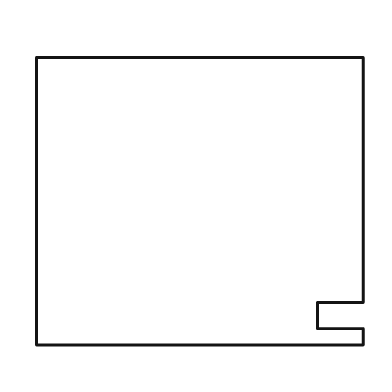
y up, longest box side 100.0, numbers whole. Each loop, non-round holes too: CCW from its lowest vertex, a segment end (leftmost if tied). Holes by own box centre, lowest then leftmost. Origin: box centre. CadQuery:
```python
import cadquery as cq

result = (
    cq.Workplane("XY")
    .moveTo(-50.0, -44.0)
    .lineTo(50.0, -44.0)
    .lineTo(50.0, -39.0)
    .lineTo(36.0, -39.0)
    .lineTo(36.0, -31.0)
    .lineTo(50.0, -31.0)
    .lineTo(50.0, 44.0)
    .lineTo(-50.0, 44.0)
    .close()
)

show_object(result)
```